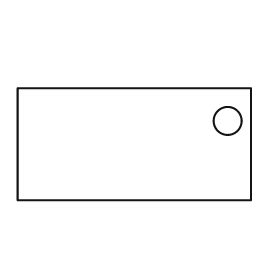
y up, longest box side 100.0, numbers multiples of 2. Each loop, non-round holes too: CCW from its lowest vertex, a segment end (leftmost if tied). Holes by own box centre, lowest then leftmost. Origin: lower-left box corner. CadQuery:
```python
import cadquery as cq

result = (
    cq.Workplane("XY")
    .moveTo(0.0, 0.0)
    .lineTo(100.0, 0.0)
    .lineTo(100.0, 48.0)
    .lineTo(0.0, 48.0)
    .close()
    .moveTo(90.0, 34.0)
    .circle(6.0)
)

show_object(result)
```